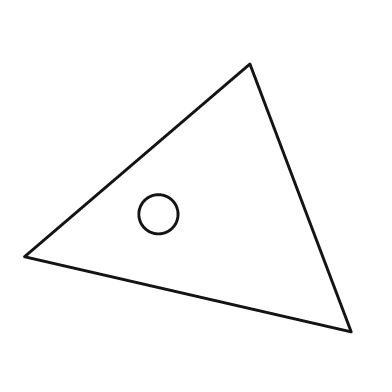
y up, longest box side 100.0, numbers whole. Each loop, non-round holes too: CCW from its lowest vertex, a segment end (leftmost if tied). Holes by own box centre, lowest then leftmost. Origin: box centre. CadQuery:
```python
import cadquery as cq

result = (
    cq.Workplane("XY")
    .moveTo(50.0, -41.0)
    .lineTo(19.0, 41.0)
    .lineTo(-50.0, -18.0)
    .close()
    .moveTo(-9.0, -5.0)
    .circle(6.0)
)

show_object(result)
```